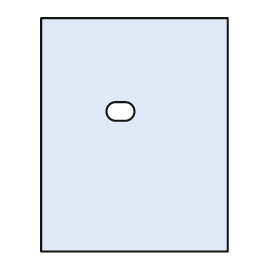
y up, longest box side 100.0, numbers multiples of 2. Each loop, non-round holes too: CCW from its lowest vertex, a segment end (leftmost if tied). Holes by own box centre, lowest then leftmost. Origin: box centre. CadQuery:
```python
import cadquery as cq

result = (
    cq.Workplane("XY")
    .moveTo(-40.0, -50.0)
    .lineTo(40.0, -50.0)
    .lineTo(40.0, 50.0)
    .lineTo(-40.0, 50.0)
    .close()
    .moveTo(-8.0, 6.0)
    .lineTo(-4.0, 6.0)
    .threePointArc((0.0, 10.0), (-4.0, 14.0))
    .lineTo(-8.0, 14.0)
    .threePointArc((-12.0, 10.0), (-8.0, 6.0))
    .close()
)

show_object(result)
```